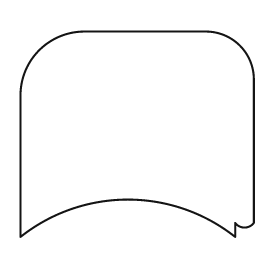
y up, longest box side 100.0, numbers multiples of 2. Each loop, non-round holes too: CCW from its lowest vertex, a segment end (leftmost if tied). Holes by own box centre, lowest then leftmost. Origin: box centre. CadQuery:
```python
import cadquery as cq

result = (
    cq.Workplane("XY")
    .moveTo(-50.0, -44.0)
    .threePointArc((-4.0, -28.0), (42.0, -44.0))
    .lineTo(42.0, -38.0)
    .threePointArc((46.0, -40.0), (50.0, -38.0))
    .lineTo(50.0, 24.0)
    .threePointArc((44.0, 38.0), (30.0, 44.0))
    .lineTo(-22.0, 44.0)
    .threePointArc((-42.0, 36.0), (-50.0, 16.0))
    .close()
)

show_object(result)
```